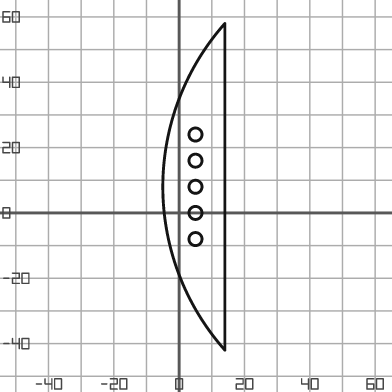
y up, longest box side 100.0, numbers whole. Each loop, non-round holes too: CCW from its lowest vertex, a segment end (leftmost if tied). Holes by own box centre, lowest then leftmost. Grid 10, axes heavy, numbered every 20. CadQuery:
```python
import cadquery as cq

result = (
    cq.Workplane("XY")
    .moveTo(14.0, -42.0)
    .lineTo(14.0, 58.0)
    .threePointArc((-5.0, 8.0), (14.0, -42.0))
    .close()
    .moveTo(5.0, -8.0)
    .circle(2.0)
    .moveTo(5.0, 0.0)
    .circle(2.0)
    .moveTo(5.0, 8.0)
    .circle(2.0)
    .moveTo(5.0, 16.0)
    .circle(2.0)
    .moveTo(5.0, 24.0)
    .circle(2.0)
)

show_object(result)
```